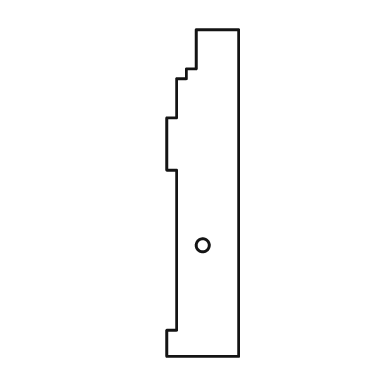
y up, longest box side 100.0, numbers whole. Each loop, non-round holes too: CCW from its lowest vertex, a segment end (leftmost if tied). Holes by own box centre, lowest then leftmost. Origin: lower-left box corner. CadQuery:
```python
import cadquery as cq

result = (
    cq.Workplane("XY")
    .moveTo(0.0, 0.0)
    .lineTo(22.0, 0.0)
    .lineTo(22.0, 100.0)
    .lineTo(9.0, 100.0)
    .lineTo(9.0, 88.0)
    .lineTo(6.0, 88.0)
    .lineTo(6.0, 85.0)
    .lineTo(3.0, 85.0)
    .lineTo(3.0, 73.0)
    .lineTo(0.0, 73.0)
    .lineTo(0.0, 57.0)
    .lineTo(3.0, 57.0)
    .lineTo(3.0, 8.0)
    .lineTo(0.0, 8.0)
    .close()
    .moveTo(11.0, 34.0)
    .circle(2.0)
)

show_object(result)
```